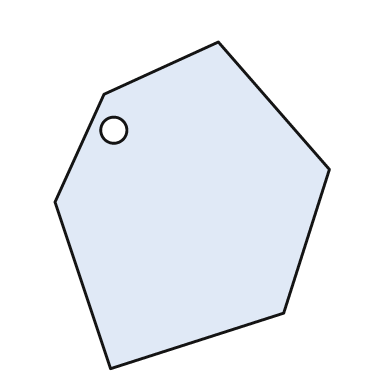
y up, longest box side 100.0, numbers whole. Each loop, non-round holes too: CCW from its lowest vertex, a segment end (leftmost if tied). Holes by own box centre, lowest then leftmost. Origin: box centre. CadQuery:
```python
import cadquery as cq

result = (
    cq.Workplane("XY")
    .moveTo(-25.0, -50.0)
    .lineTo(28.0, -33.0)
    .lineTo(42.0, 11.0)
    .lineTo(8.0, 50.0)
    .lineTo(-27.0, 34.0)
    .lineTo(-42.0, 1.0)
    .close()
    .moveTo(-24.0, 23.0)
    .circle(4.0)
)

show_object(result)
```